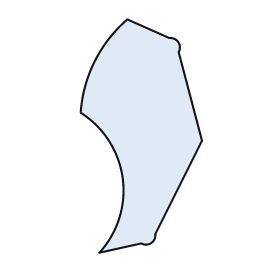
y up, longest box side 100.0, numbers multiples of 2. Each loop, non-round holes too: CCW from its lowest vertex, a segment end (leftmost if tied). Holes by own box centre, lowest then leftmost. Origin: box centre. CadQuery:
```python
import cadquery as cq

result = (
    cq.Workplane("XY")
    .moveTo(-18.0, -50.0)
    .lineTo(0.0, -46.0)
    .threePointArc((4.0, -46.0), (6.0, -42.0))
    .lineTo(26.0, -2.0)
    .lineTo(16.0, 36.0)
    .threePointArc((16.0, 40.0), (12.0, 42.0))
    .lineTo(-6.0, 50.0)
    .threePointArc((-20.0, 32.0), (-26.0, 10.0))
    .threePointArc((-8.0, -18.0), (-18.0, -50.0))
    .close()
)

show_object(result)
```